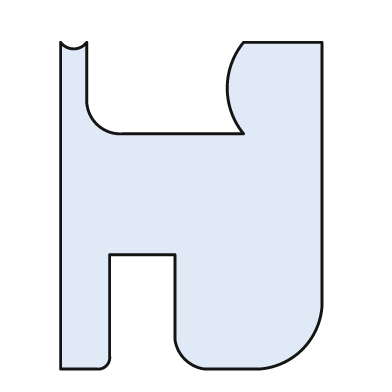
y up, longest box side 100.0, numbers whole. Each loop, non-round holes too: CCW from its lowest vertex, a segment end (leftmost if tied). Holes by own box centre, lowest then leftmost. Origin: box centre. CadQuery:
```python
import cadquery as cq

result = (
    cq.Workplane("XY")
    .moveTo(-40.0, -50.0)
    .lineTo(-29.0, -50.0)
    .threePointArc((-26.0, -49.0), (-25.0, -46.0))
    .lineTo(-25.0, -15.0)
    .lineTo(-5.0, -15.0)
    .lineTo(-5.0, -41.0)
    .threePointArc((-2.0, -47.0), (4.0, -50.0))
    .lineTo(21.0, -50.0)
    .threePointArc((34.0, -44.0), (40.0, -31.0))
    .lineTo(40.0, 50.0)
    .lineTo(16.0, 50.0)
    .threePointArc((11.0, 36.0), (16.0, 22.0))
    .lineTo(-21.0, 22.0)
    .threePointArc((-29.0, 25.0), (-32.0, 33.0))
    .lineTo(-32.0, 50.0)
    .threePointArc((-36.0, 48.0), (-40.0, 50.0))
    .close()
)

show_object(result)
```